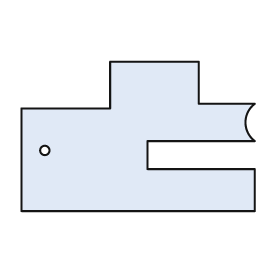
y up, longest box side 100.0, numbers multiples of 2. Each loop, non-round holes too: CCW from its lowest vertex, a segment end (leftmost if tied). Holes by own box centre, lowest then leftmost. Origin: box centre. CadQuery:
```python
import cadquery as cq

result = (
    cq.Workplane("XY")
    .moveTo(-50.0, -32.0)
    .lineTo(50.0, -32.0)
    .lineTo(50.0, -14.0)
    .lineTo(4.0, -14.0)
    .lineTo(4.0, -2.0)
    .lineTo(50.0, -2.0)
    .threePointArc((46.0, 6.0), (50.0, 14.0))
    .lineTo(26.0, 14.0)
    .lineTo(26.0, 32.0)
    .lineTo(-12.0, 32.0)
    .lineTo(-12.0, 12.0)
    .lineTo(-50.0, 12.0)
    .close()
    .moveTo(-40.0, -6.0)
    .circle(2.0)
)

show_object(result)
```